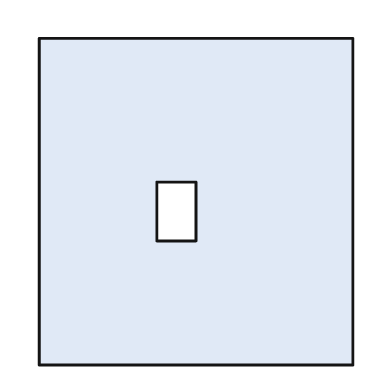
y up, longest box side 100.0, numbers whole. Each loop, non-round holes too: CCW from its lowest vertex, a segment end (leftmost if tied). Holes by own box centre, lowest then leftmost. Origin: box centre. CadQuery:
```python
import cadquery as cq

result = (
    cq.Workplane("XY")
    .moveTo(-48.0, -50.0)
    .lineTo(48.0, -50.0)
    .lineTo(48.0, 50.0)
    .lineTo(-48.0, 50.0)
    .close()
    .moveTo(-12.0, -12.0)
    .lineTo(0.0, -12.0)
    .lineTo(0.0, 6.0)
    .lineTo(-12.0, 6.0)
    .close()
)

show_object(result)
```